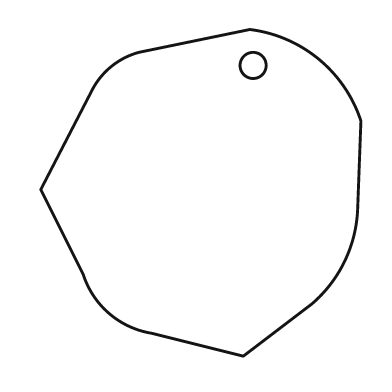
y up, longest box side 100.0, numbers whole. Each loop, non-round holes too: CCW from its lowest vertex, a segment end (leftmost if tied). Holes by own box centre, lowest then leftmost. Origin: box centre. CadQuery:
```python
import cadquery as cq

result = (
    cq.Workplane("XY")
    .moveTo(13.0, -50.0)
    .lineTo(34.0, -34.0)
    .threePointArc((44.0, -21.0), (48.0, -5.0))
    .lineTo(49.0, 22.0)
    .threePointArc((36.0, 41.0), (15.0, 50.0))
    .lineTo(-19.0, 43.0)
    .threePointArc((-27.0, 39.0), (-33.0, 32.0))
    .lineTo(-49.0, 1.0)
    .lineTo(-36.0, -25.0)
    .threePointArc((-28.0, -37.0), (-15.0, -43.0))
    .close()
    .moveTo(16.0, 39.0)
    .circle(4.0)
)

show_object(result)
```